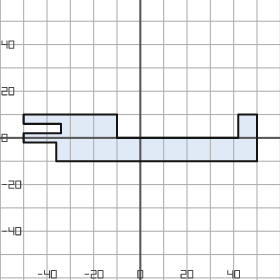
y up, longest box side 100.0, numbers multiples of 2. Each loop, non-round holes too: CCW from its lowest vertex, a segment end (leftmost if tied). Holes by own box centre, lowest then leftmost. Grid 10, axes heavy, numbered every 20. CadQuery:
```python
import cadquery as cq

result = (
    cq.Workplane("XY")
    .moveTo(-36.0, -10.0)
    .lineTo(50.0, -10.0)
    .lineTo(50.0, 10.0)
    .lineTo(42.0, 10.0)
    .lineTo(42.0, 0.0)
    .lineTo(-10.0, 0.0)
    .lineTo(-10.0, 10.0)
    .lineTo(-50.0, 10.0)
    .lineTo(-50.0, 6.0)
    .lineTo(-34.0, 6.0)
    .lineTo(-34.0, 2.0)
    .lineTo(-50.0, 2.0)
    .lineTo(-50.0, -2.0)
    .lineTo(-36.0, -2.0)
    .close()
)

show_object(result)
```